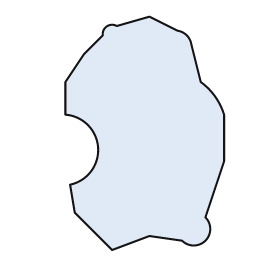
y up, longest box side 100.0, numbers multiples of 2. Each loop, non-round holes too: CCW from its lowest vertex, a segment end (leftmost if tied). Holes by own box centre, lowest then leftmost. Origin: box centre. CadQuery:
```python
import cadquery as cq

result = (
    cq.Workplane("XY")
    .moveTo(-14.0, -50.0)
    .lineTo(2.0, -44.0)
    .lineTo(16.0, -46.0)
    .threePointArc((26.0, -46.0), (26.0, -36.0))
    .lineTo(34.0, -12.0)
    .lineTo(34.0, 8.0)
    .threePointArc((30.0, 16.0), (24.0, 22.0))
    .lineTo(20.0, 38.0)
    .threePointArc((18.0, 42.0), (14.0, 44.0))
    .lineTo(2.0, 50.0)
    .lineTo(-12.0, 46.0)
    .threePointArc((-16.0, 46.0), (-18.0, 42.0))
    .lineTo(-26.0, 34.0)
    .lineTo(-34.0, 22.0)
    .lineTo(-34.0, 8.0)
    .threePointArc((-20.0, -6.0), (-32.0, -22.0))
    .lineTo(-30.0, -34.0)
    .close()
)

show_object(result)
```